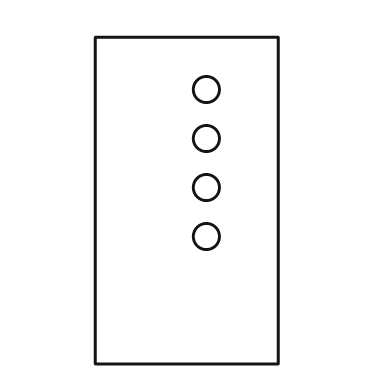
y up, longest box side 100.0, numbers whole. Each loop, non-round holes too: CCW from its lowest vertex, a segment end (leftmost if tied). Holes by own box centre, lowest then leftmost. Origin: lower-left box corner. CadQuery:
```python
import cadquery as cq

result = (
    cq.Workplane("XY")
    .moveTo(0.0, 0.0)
    .lineTo(56.0, 0.0)
    .lineTo(56.0, 100.0)
    .lineTo(0.0, 100.0)
    .close()
    .moveTo(34.0, 39.0)
    .circle(4.0)
    .moveTo(34.0, 54.0)
    .circle(4.0)
    .moveTo(34.0, 69.0)
    .circle(4.0)
    .moveTo(34.0, 84.0)
    .circle(4.0)
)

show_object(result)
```